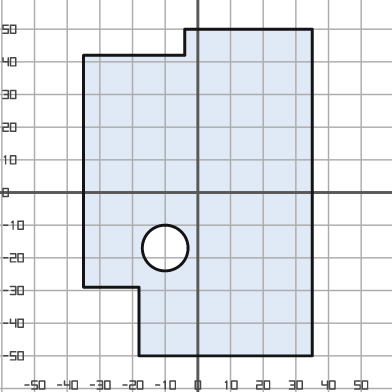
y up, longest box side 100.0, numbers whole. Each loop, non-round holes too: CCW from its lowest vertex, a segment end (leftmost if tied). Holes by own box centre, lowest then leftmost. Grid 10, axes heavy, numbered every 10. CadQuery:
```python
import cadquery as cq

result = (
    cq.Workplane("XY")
    .moveTo(-18.0, -50.0)
    .lineTo(35.0, -50.0)
    .lineTo(35.0, 50.0)
    .lineTo(-4.0, 50.0)
    .lineTo(-4.0, 42.0)
    .lineTo(-35.0, 42.0)
    .lineTo(-35.0, -29.0)
    .lineTo(-18.0, -29.0)
    .close()
    .moveTo(-10.0, -17.0)
    .circle(7.0)
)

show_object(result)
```